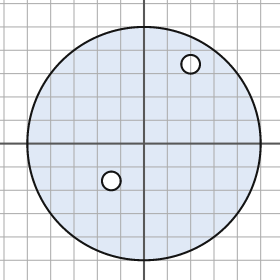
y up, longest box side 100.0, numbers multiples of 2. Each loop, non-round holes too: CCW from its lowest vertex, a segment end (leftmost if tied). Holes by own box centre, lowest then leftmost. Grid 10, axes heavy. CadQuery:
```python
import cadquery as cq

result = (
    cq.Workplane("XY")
    .moveTo(0.0, 0.0)
    .circle(50.0)
    .moveTo(-14.0, -16.0)
    .circle(4.0)
    .moveTo(20.0, 34.0)
    .circle(4.0)
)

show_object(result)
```